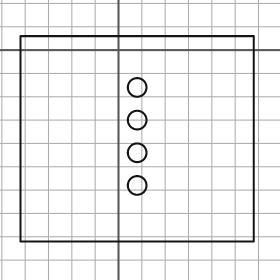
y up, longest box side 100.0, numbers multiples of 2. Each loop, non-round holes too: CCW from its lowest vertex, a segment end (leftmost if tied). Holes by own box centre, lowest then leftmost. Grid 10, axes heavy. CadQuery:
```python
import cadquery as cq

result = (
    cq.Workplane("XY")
    .moveTo(-42.0, -82.0)
    .lineTo(58.0, -82.0)
    .lineTo(58.0, 6.0)
    .lineTo(-42.0, 6.0)
    .close()
    .moveTo(8.0, -58.0)
    .circle(4.0)
    .moveTo(8.0, -44.0)
    .circle(4.0)
    .moveTo(8.0, -30.0)
    .circle(4.0)
    .moveTo(8.0, -16.0)
    .circle(4.0)
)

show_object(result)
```